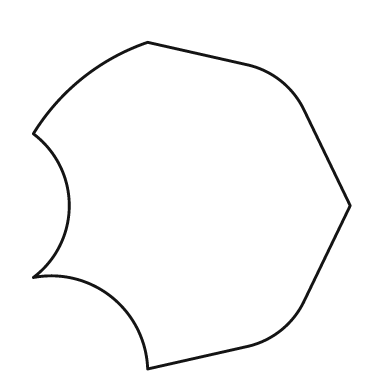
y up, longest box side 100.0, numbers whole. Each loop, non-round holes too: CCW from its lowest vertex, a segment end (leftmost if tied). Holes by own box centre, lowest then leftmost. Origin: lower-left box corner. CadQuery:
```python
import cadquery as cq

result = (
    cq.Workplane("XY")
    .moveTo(35.0, 0.0)
    .lineTo(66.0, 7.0)
    .threePointArc((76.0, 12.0), (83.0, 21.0))
    .lineTo(97.0, 50.0)
    .lineTo(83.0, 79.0)
    .threePointArc((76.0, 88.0), (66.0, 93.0))
    .lineTo(35.0, 100.0)
    .threePointArc((15.0, 89.0), (0.0, 72.0))
    .threePointArc((11.0, 50.0), (0.0, 28.0))
    .threePointArc((24.0, 22.0), (35.0, 0.0))
    .close()
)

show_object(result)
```